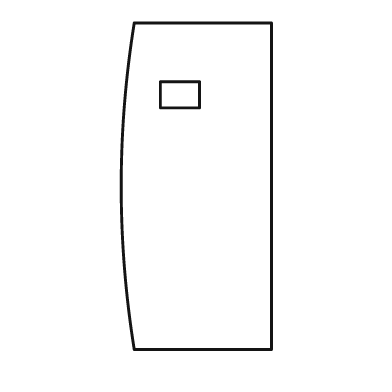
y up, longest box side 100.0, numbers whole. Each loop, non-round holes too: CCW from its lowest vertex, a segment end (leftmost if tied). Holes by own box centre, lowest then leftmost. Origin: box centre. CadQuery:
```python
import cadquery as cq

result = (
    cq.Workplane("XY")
    .moveTo(-19.0, -50.0)
    .lineTo(23.0, -50.0)
    .lineTo(23.0, 50.0)
    .lineTo(-19.0, 50.0)
    .threePointArc((-23.0, 0.0), (-19.0, -50.0))
    .close()
    .moveTo(-11.0, 24.0)
    .lineTo(1.0, 24.0)
    .lineTo(1.0, 32.0)
    .lineTo(-11.0, 32.0)
    .close()
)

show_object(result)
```